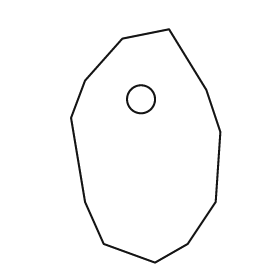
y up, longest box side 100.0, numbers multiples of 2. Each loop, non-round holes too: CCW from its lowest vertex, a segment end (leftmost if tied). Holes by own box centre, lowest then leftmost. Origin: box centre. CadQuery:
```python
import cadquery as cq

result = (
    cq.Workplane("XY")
    .moveTo(4.0, -50.0)
    .lineTo(18.0, -42.0)
    .lineTo(30.0, -24.0)
    .lineTo(32.0, 6.0)
    .lineTo(26.0, 24.0)
    .lineTo(10.0, 50.0)
    .lineTo(-10.0, 46.0)
    .lineTo(-26.0, 28.0)
    .lineTo(-32.0, 12.0)
    .lineTo(-26.0, -24.0)
    .lineTo(-18.0, -42.0)
    .close()
    .moveTo(-2.0, 20.0)
    .circle(6.0)
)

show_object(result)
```